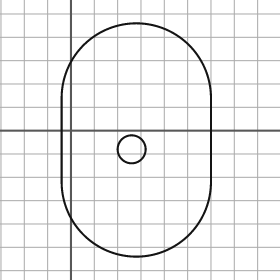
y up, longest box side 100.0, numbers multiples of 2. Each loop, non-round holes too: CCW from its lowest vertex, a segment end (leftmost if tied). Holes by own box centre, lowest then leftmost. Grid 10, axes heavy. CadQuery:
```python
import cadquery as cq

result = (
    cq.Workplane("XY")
    .moveTo(-4.0, -22.0)
    .threePointArc((28.0, -54.0), (60.0, -22.0))
    .lineTo(60.0, 14.0)
    .threePointArc((28.0, 46.0), (-4.0, 14.0))
    .close()
    .moveTo(26.0, -8.0)
    .circle(6.0)
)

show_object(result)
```